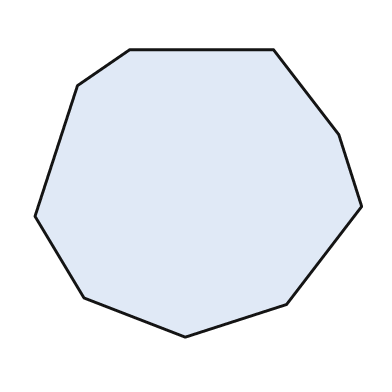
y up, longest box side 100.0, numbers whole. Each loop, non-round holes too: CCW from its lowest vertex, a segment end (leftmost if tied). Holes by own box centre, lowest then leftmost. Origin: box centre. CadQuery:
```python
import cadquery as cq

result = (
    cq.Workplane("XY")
    .moveTo(-4.0, -44.0)
    .lineTo(27.0, -34.0)
    .lineTo(50.0, -4.0)
    .lineTo(43.0, 18.0)
    .lineTo(23.0, 44.0)
    .lineTo(-21.0, 44.0)
    .lineTo(-37.0, 33.0)
    .lineTo(-50.0, -7.0)
    .lineTo(-35.0, -32.0)
    .close()
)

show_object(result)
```